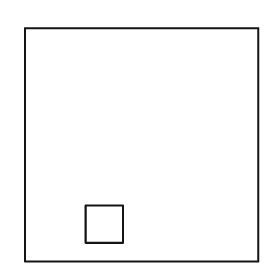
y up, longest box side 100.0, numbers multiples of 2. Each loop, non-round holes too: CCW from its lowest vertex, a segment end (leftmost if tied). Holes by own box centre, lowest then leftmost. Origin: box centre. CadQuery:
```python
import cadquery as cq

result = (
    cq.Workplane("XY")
    .moveTo(-50.0, -50.0)
    .lineTo(50.0, -50.0)
    .lineTo(50.0, 50.0)
    .lineTo(-50.0, 50.0)
    .close()
    .moveTo(-24.0, -42.0)
    .lineTo(-8.0, -42.0)
    .lineTo(-8.0, -26.0)
    .lineTo(-24.0, -26.0)
    .close()
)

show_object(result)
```